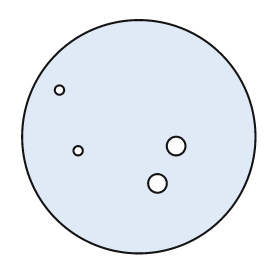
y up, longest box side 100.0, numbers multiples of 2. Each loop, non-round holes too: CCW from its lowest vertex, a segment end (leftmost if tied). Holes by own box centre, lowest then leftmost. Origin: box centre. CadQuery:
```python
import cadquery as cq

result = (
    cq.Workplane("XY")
    .moveTo(0.0, 0.0)
    .circle(50.0)
    .moveTo(8.0, -20.0)
    .circle(4.0)
    .moveTo(-26.0, -6.0)
    .circle(2.0)
    .moveTo(16.0, -4.0)
    .circle(4.0)
    .moveTo(-34.0, 20.0)
    .circle(2.0)
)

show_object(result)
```